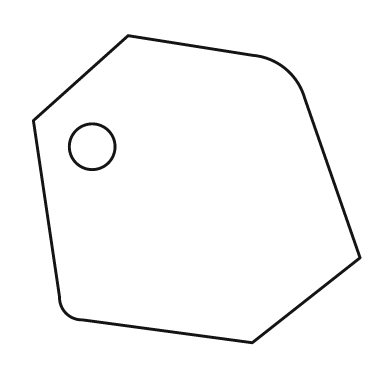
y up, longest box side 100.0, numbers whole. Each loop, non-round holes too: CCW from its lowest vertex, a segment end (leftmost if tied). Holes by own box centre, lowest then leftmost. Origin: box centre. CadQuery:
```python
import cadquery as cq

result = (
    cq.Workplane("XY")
    .moveTo(17.0, -47.0)
    .lineTo(50.0, -21.0)
    .lineTo(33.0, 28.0)
    .threePointArc((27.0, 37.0), (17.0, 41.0))
    .lineTo(-21.0, 47.0)
    .lineTo(-50.0, 21.0)
    .lineTo(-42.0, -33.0)
    .threePointArc((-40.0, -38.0), (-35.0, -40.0))
    .close()
    .moveTo(-32.0, 13.0)
    .circle(7.0)
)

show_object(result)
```